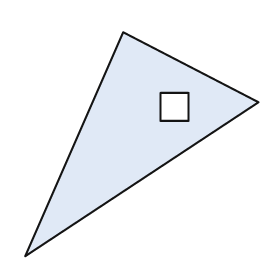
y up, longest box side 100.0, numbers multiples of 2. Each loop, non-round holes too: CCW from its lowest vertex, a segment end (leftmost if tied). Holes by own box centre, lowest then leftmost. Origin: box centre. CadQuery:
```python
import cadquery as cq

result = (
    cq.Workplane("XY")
    .moveTo(-50.0, -48.0)
    .lineTo(50.0, 18.0)
    .lineTo(-8.0, 48.0)
    .close()
    .moveTo(8.0, 10.0)
    .lineTo(20.0, 10.0)
    .lineTo(20.0, 22.0)
    .lineTo(8.0, 22.0)
    .close()
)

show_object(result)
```